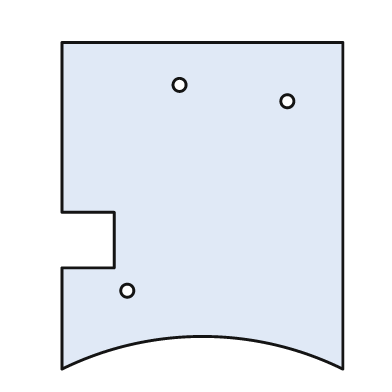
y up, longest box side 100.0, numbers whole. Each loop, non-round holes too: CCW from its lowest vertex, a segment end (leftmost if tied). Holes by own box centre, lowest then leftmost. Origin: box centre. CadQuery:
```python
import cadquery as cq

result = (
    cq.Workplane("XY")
    .moveTo(-43.0, -50.0)
    .threePointArc((0.0, -40.0), (43.0, -50.0))
    .lineTo(43.0, 50.0)
    .lineTo(-43.0, 50.0)
    .lineTo(-43.0, -2.0)
    .lineTo(-27.0, -2.0)
    .lineTo(-27.0, -19.0)
    .lineTo(-43.0, -19.0)
    .close()
    .moveTo(-23.0, -26.0)
    .circle(2.0)
    .moveTo(26.0, 32.0)
    .circle(2.0)
    .moveTo(-7.0, 37.0)
    .circle(2.0)
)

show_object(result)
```